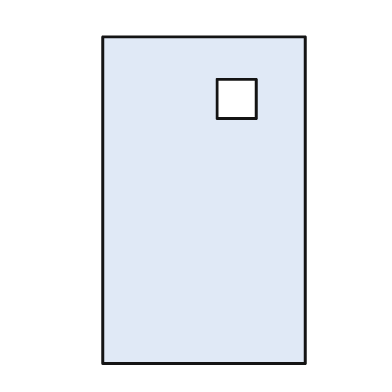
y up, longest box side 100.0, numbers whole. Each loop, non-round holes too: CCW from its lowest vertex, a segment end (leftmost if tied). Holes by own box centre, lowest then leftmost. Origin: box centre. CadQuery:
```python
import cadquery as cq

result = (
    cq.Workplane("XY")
    .moveTo(-31.0, -50.0)
    .lineTo(31.0, -50.0)
    .lineTo(31.0, 50.0)
    .lineTo(-31.0, 50.0)
    .close()
    .moveTo(4.0, 25.0)
    .lineTo(16.0, 25.0)
    .lineTo(16.0, 37.0)
    .lineTo(4.0, 37.0)
    .close()
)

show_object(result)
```